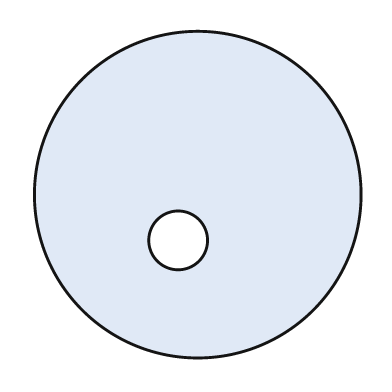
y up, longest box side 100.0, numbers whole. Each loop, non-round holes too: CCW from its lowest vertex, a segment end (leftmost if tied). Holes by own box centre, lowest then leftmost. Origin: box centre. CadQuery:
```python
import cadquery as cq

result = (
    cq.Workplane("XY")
    .moveTo(0.0, 0.0)
    .circle(50.0)
    .moveTo(-6.0, -14.0)
    .circle(9.0)
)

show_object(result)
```